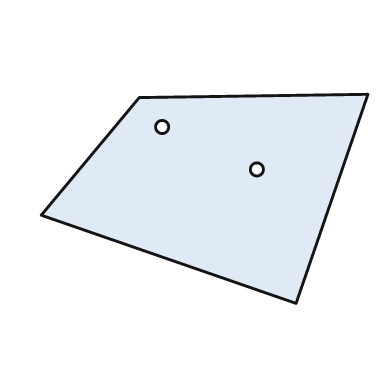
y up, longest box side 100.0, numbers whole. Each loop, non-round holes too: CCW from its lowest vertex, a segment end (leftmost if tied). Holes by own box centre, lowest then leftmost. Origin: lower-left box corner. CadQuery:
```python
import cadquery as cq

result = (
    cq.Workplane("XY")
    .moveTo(78.0, 0.0)
    .lineTo(100.0, 64.0)
    .lineTo(30.0, 63.0)
    .lineTo(0.0, 27.0)
    .close()
    .moveTo(66.0, 41.0)
    .circle(2.0)
    .moveTo(37.0, 54.0)
    .circle(2.0)
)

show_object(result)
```